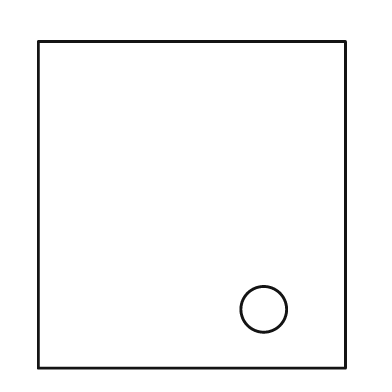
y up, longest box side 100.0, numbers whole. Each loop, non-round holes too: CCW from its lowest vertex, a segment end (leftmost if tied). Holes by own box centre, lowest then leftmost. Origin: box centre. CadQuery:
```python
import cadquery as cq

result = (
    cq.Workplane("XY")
    .moveTo(-47.0, -50.0)
    .lineTo(47.0, -50.0)
    .lineTo(47.0, 50.0)
    .lineTo(-47.0, 50.0)
    .close()
    .moveTo(22.0, -32.0)
    .circle(7.0)
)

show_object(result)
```